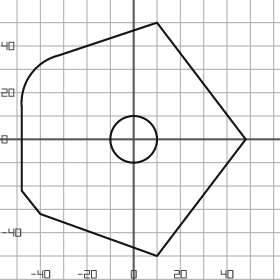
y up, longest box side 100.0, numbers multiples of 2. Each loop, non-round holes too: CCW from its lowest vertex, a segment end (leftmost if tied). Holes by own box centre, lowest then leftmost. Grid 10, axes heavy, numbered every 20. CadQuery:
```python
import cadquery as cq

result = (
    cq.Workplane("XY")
    .moveTo(10.0, -50.0)
    .lineTo(48.0, 0.0)
    .lineTo(10.0, 50.0)
    .lineTo(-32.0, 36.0)
    .threePointArc((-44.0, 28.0), (-48.0, 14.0))
    .lineTo(-48.0, -22.0)
    .lineTo(-40.0, -32.0)
    .close()
    .moveTo(0.0, 0.0)
    .circle(10.0)
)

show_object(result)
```